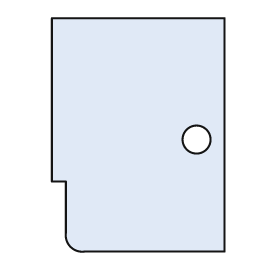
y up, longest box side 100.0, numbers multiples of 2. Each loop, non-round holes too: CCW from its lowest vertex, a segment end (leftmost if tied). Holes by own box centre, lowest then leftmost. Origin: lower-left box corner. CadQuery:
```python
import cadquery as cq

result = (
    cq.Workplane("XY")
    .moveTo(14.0, 0.0)
    .lineTo(74.0, 0.0)
    .lineTo(74.0, 100.0)
    .lineTo(0.0, 100.0)
    .lineTo(0.0, 30.0)
    .lineTo(6.0, 30.0)
    .lineTo(6.0, 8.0)
    .threePointArc((8.0, 2.0), (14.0, 0.0))
    .close()
    .moveTo(62.0, 48.0)
    .circle(6.0)
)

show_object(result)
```